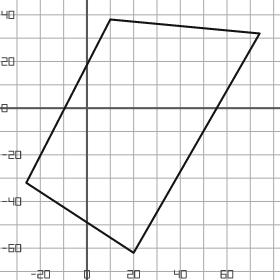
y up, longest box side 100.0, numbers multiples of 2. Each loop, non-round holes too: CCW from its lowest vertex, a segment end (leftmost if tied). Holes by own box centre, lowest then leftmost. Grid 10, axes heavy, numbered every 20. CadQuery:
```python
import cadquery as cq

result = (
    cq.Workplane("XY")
    .moveTo(20.0, -62.0)
    .lineTo(74.0, 32.0)
    .lineTo(10.0, 38.0)
    .lineTo(-26.0, -32.0)
    .close()
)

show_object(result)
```